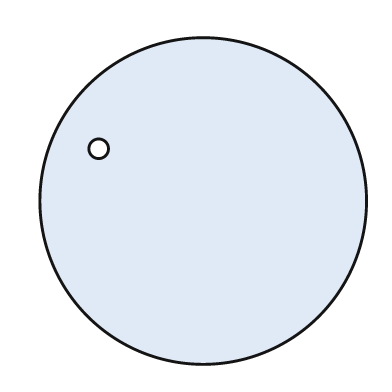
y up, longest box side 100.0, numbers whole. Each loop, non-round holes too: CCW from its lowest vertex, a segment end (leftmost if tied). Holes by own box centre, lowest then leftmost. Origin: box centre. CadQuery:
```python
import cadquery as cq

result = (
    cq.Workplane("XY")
    .moveTo(0.0, 0.0)
    .circle(50.0)
    .moveTo(-32.0, 16.0)
    .circle(3.0)
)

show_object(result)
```